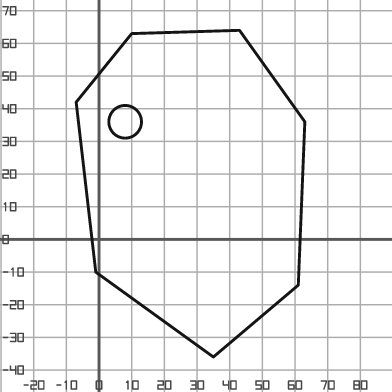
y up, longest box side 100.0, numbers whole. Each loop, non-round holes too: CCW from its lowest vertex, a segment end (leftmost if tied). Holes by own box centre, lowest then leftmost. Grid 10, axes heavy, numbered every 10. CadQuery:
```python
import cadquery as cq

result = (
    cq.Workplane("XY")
    .moveTo(35.0, -36.0)
    .lineTo(61.0, -14.0)
    .lineTo(63.0, 36.0)
    .lineTo(43.0, 64.0)
    .lineTo(10.0, 63.0)
    .lineTo(-7.0, 42.0)
    .lineTo(-1.0, -10.0)
    .close()
    .moveTo(8.0, 36.0)
    .circle(5.0)
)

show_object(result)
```